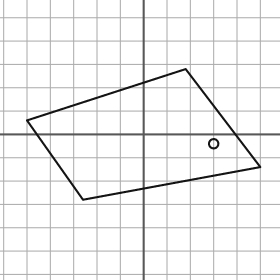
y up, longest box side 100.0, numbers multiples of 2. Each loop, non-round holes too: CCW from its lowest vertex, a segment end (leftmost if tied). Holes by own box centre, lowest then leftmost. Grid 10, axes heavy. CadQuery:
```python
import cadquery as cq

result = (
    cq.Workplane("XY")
    .moveTo(-26.0, -28.0)
    .lineTo(50.0, -14.0)
    .lineTo(18.0, 28.0)
    .lineTo(-50.0, 6.0)
    .close()
    .moveTo(30.0, -4.0)
    .circle(2.0)
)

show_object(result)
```